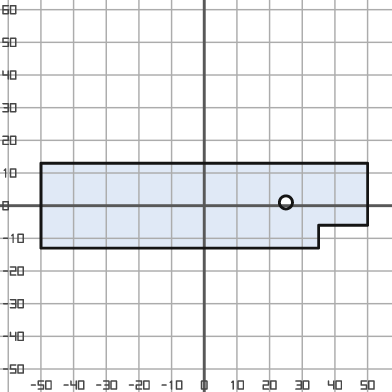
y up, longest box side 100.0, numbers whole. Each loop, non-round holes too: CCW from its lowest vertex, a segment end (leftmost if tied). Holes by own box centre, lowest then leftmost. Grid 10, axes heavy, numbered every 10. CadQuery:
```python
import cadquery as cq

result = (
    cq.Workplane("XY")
    .moveTo(-50.0, -13.0)
    .lineTo(35.0, -13.0)
    .lineTo(35.0, -6.0)
    .lineTo(50.0, -6.0)
    .lineTo(50.0, 13.0)
    .lineTo(-50.0, 13.0)
    .close()
    .moveTo(25.0, 1.0)
    .circle(2.0)
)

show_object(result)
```